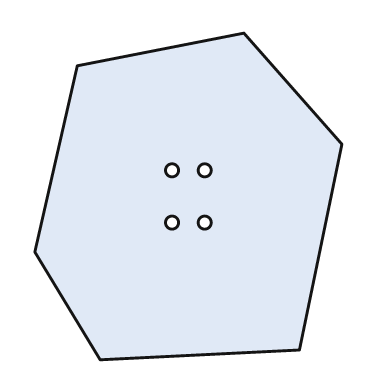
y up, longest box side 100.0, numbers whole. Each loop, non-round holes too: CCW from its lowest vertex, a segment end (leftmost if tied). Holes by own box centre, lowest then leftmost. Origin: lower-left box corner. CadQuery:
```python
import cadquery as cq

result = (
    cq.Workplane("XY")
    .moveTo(20.0, 0.0)
    .lineTo(81.0, 3.0)
    .lineTo(94.0, 66.0)
    .lineTo(64.0, 100.0)
    .lineTo(13.0, 90.0)
    .lineTo(0.0, 33.0)
    .close()
    .moveTo(42.0, 42.0)
    .circle(2.0)
    .moveTo(52.0, 42.0)
    .circle(2.0)
    .moveTo(42.0, 58.0)
    .circle(2.0)
    .moveTo(52.0, 58.0)
    .circle(2.0)
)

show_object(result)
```